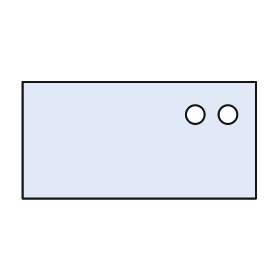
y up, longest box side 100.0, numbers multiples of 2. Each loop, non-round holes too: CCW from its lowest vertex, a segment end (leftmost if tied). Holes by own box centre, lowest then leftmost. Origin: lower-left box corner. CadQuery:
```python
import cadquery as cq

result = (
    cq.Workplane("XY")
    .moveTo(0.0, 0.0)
    .lineTo(100.0, 0.0)
    .lineTo(100.0, 50.0)
    .lineTo(0.0, 50.0)
    .close()
    .moveTo(74.0, 36.0)
    .circle(4.0)
    .moveTo(88.0, 36.0)
    .circle(4.0)
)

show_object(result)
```